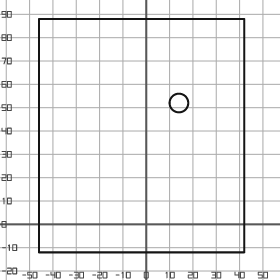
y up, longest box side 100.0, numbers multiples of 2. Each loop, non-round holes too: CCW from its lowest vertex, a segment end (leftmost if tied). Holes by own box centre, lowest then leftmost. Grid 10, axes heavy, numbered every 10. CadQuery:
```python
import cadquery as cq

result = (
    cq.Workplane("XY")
    .moveTo(-46.0, -12.0)
    .lineTo(42.0, -12.0)
    .lineTo(42.0, 88.0)
    .lineTo(-46.0, 88.0)
    .close()
    .moveTo(14.0, 52.0)
    .circle(4.0)
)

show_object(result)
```